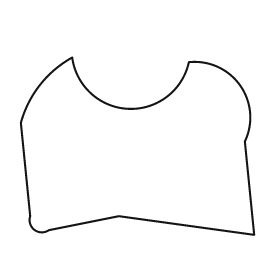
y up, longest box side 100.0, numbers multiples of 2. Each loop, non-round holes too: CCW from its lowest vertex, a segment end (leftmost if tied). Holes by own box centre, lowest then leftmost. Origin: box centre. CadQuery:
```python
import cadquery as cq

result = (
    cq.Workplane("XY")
    .moveTo(50.0, -38.0)
    .lineTo(46.0, 2.0)
    .threePointArc((44.0, 26.0), (22.0, 36.0))
    .threePointArc((-4.0, 16.0), (-28.0, 38.0))
    .threePointArc((-42.0, 26.0), (-50.0, 10.0))
    .lineTo(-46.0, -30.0)
    .threePointArc((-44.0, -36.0), (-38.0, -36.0))
    .lineTo(-8.0, -30.0)
    .close()
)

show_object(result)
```